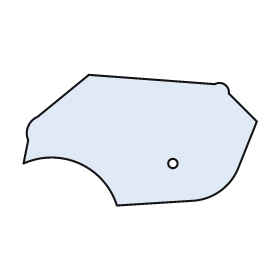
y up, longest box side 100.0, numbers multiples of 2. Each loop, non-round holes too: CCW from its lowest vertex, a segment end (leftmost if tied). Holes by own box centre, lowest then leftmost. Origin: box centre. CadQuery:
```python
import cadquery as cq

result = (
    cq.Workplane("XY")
    .moveTo(-10.0, -28.0)
    .lineTo(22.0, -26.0)
    .threePointArc((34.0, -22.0), (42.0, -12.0))
    .lineTo(50.0, 8.0)
    .lineTo(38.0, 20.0)
    .threePointArc((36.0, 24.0), (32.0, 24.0))
    .lineTo(-22.0, 28.0)
    .lineTo(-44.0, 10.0)
    .threePointArc((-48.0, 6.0), (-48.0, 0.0))
    .lineTo(-50.0, -10.0)
    .threePointArc((-26.0, -10.0), (-10.0, -28.0))
    .close()
    .moveTo(14.0, -10.0)
    .circle(2.0)
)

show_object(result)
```